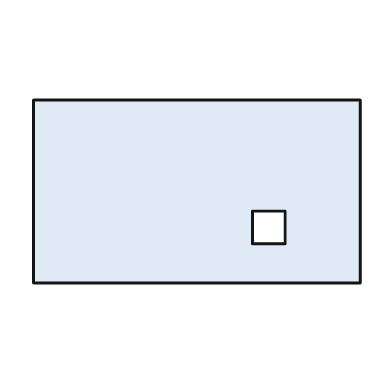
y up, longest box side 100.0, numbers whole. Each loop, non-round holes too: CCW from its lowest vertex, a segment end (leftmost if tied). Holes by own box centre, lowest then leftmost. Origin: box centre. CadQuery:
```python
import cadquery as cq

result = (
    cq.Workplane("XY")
    .moveTo(-50.0, -28.0)
    .lineTo(50.0, -28.0)
    .lineTo(50.0, 28.0)
    .lineTo(-50.0, 28.0)
    .close()
    .moveTo(17.0, -16.0)
    .lineTo(27.0, -16.0)
    .lineTo(27.0, -6.0)
    .lineTo(17.0, -6.0)
    .close()
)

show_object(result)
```